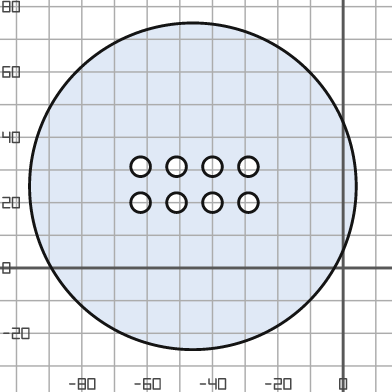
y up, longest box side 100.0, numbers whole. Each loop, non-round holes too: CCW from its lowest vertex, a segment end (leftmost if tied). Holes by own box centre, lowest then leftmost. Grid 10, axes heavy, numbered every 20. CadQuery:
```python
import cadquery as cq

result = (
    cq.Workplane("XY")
    .moveTo(-46.0, 25.0)
    .circle(50.0)
    .moveTo(-62.0, 20.0)
    .circle(3.0)
    .moveTo(-51.0, 20.0)
    .circle(3.0)
    .moveTo(-40.0, 20.0)
    .circle(3.0)
    .moveTo(-29.0, 20.0)
    .circle(3.0)
    .moveTo(-62.0, 31.0)
    .circle(3.0)
    .moveTo(-51.0, 31.0)
    .circle(3.0)
    .moveTo(-40.0, 31.0)
    .circle(3.0)
    .moveTo(-29.0, 31.0)
    .circle(3.0)
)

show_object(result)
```